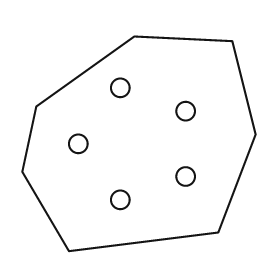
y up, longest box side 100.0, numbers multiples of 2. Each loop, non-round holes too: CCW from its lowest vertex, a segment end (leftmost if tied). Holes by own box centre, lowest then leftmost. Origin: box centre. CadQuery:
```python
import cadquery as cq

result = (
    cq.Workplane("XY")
    .moveTo(-30.0, -46.0)
    .lineTo(34.0, -38.0)
    .lineTo(50.0, 4.0)
    .lineTo(40.0, 44.0)
    .lineTo(-2.0, 46.0)
    .lineTo(-44.0, 16.0)
    .lineTo(-50.0, -12.0)
    .close()
    .moveTo(-8.0, -24.0)
    .circle(4.0)
    .moveTo(20.0, -14.0)
    .circle(4.0)
    .moveTo(-26.0, 0.0)
    .circle(4.0)
    .moveTo(20.0, 14.0)
    .circle(4.0)
    .moveTo(-8.0, 24.0)
    .circle(4.0)
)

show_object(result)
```